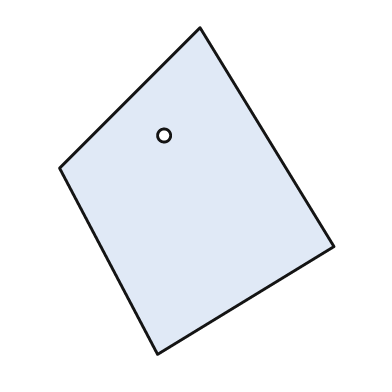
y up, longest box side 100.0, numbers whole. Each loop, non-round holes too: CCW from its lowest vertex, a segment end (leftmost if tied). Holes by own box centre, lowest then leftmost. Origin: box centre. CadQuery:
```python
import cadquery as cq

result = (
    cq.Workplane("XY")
    .moveTo(-12.0, -50.0)
    .lineTo(42.0, -17.0)
    .lineTo(1.0, 50.0)
    .lineTo(-42.0, 7.0)
    .close()
    .moveTo(-10.0, 17.0)
    .circle(2.0)
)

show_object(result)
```